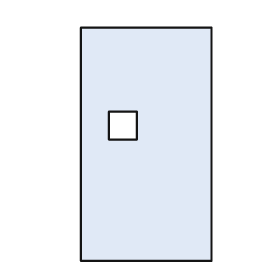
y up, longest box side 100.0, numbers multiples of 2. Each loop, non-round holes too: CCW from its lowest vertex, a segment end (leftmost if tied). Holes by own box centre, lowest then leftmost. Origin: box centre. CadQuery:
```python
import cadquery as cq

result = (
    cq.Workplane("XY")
    .moveTo(-28.0, -50.0)
    .lineTo(28.0, -50.0)
    .lineTo(28.0, 50.0)
    .lineTo(-28.0, 50.0)
    .close()
    .moveTo(-16.0, 2.0)
    .lineTo(-4.0, 2.0)
    .lineTo(-4.0, 14.0)
    .lineTo(-16.0, 14.0)
    .close()
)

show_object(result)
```